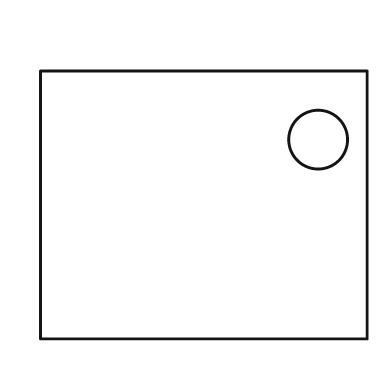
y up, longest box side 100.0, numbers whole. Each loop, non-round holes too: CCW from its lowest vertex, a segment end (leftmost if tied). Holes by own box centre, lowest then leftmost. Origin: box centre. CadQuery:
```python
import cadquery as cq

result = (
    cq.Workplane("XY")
    .moveTo(-50.0, -41.0)
    .lineTo(50.0, -41.0)
    .lineTo(50.0, 41.0)
    .lineTo(-50.0, 41.0)
    .close()
    .moveTo(35.0, 20.0)
    .circle(9.0)
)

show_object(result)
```